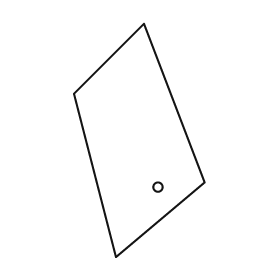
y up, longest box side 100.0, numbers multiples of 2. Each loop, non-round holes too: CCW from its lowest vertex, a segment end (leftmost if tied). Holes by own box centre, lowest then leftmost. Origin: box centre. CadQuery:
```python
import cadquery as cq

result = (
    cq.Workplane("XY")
    .moveTo(-10.0, -50.0)
    .lineTo(28.0, -18.0)
    .lineTo(2.0, 50.0)
    .lineTo(-28.0, 20.0)
    .close()
    .moveTo(8.0, -20.0)
    .circle(2.0)
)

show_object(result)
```